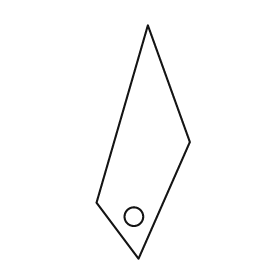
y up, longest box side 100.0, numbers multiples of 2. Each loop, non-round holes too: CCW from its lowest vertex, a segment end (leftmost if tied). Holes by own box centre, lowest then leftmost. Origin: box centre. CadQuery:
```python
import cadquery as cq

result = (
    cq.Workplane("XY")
    .moveTo(-2.0, -50.0)
    .lineTo(20.0, 0.0)
    .lineTo(2.0, 50.0)
    .lineTo(-20.0, -26.0)
    .close()
    .moveTo(-4.0, -32.0)
    .circle(4.0)
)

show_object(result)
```